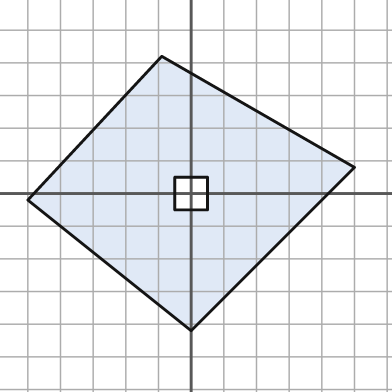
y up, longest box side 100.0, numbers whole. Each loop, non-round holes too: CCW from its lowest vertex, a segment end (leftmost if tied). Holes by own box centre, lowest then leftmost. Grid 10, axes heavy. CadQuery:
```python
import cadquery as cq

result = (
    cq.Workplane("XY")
    .moveTo(0.0, -42.0)
    .lineTo(50.0, 8.0)
    .lineTo(-9.0, 42.0)
    .lineTo(-50.0, -2.0)
    .close()
    .moveTo(-5.0, -5.0)
    .lineTo(5.0, -5.0)
    .lineTo(5.0, 5.0)
    .lineTo(-5.0, 5.0)
    .close()
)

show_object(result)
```